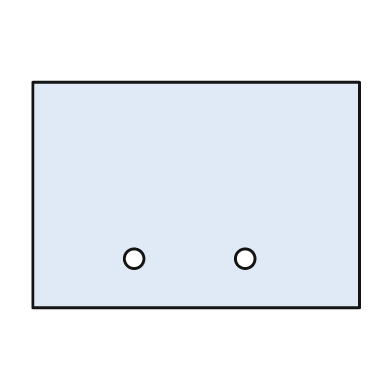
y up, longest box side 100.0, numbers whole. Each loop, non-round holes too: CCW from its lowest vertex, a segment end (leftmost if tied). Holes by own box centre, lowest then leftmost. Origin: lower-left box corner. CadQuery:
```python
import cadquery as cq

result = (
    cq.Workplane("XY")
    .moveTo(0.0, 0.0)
    .lineTo(100.0, 0.0)
    .lineTo(100.0, 69.0)
    .lineTo(0.0, 69.0)
    .close()
    .moveTo(31.0, 15.0)
    .circle(3.0)
    .moveTo(65.0, 15.0)
    .circle(3.0)
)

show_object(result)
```